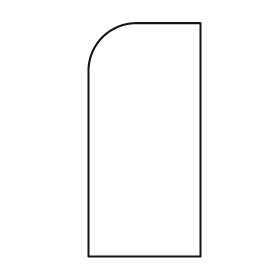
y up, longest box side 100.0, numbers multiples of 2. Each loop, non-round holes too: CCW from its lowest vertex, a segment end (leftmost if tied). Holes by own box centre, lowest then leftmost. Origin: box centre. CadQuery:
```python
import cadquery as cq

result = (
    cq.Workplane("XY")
    .moveTo(-24.0, -50.0)
    .lineTo(24.0, -50.0)
    .lineTo(24.0, 50.0)
    .lineTo(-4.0, 50.0)
    .threePointArc((-18.0, 44.0), (-24.0, 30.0))
    .close()
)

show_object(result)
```